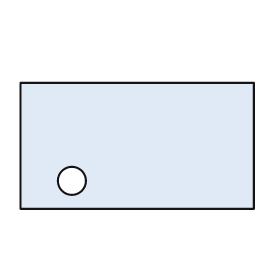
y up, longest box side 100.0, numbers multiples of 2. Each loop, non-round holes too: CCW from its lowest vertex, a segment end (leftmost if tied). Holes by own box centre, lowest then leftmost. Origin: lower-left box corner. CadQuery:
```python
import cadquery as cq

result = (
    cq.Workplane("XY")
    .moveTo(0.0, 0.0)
    .lineTo(100.0, 0.0)
    .lineTo(100.0, 54.0)
    .lineTo(0.0, 54.0)
    .close()
    .moveTo(22.0, 12.0)
    .circle(6.0)
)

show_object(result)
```